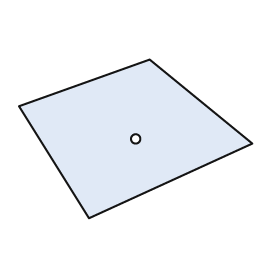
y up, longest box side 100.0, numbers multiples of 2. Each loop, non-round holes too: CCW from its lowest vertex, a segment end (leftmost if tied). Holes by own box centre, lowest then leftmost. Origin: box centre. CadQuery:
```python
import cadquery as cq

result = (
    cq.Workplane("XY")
    .moveTo(-20.0, -34.0)
    .lineTo(50.0, -2.0)
    .lineTo(6.0, 34.0)
    .lineTo(-50.0, 14.0)
    .close()
    .moveTo(0.0, 0.0)
    .circle(2.0)
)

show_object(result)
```